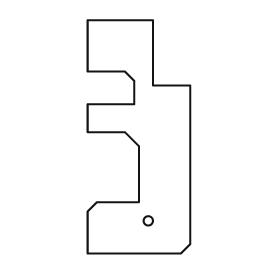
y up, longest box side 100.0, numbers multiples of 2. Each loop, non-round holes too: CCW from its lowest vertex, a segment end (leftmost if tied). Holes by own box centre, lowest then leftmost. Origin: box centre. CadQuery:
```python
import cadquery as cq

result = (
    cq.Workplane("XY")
    .moveTo(-22.0, -50.0)
    .lineTo(18.0, -50.0)
    .lineTo(22.0, -46.0)
    .lineTo(22.0, 22.0)
    .lineTo(6.0, 22.0)
    .lineTo(6.0, 50.0)
    .lineTo(-22.0, 50.0)
    .lineTo(-22.0, 28.0)
    .lineTo(-6.0, 28.0)
    .lineTo(-2.0, 24.0)
    .lineTo(-2.0, 14.0)
    .lineTo(-22.0, 14.0)
    .lineTo(-22.0, 2.0)
    .lineTo(-6.0, 2.0)
    .lineTo(0.0, -4.0)
    .lineTo(0.0, -28.0)
    .lineTo(-18.0, -28.0)
    .lineTo(-22.0, -32.0)
    .close()
    .moveTo(4.0, -36.0)
    .circle(2.0)
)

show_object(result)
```